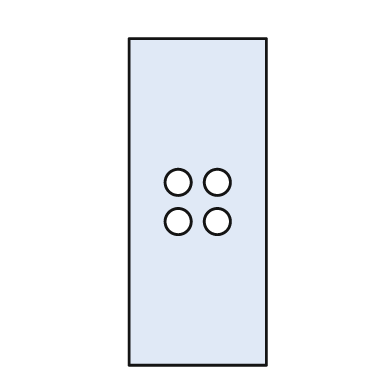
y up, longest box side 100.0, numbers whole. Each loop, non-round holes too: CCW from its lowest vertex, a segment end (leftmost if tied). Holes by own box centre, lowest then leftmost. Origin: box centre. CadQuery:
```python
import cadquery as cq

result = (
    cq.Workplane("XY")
    .moveTo(-21.0, -50.0)
    .lineTo(21.0, -50.0)
    .lineTo(21.0, 50.0)
    .lineTo(-21.0, 50.0)
    .close()
    .moveTo(-6.0, -6.0)
    .circle(4.0)
    .moveTo(6.0, -6.0)
    .circle(4.0)
    .moveTo(-6.0, 6.0)
    .circle(4.0)
    .moveTo(6.0, 6.0)
    .circle(4.0)
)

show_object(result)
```